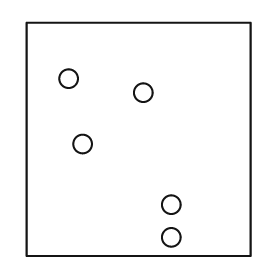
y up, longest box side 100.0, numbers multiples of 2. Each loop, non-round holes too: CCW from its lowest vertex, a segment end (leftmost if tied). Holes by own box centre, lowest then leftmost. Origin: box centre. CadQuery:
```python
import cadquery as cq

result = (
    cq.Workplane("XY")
    .moveTo(-48.0, -50.0)
    .lineTo(48.0, -50.0)
    .lineTo(48.0, 50.0)
    .lineTo(-48.0, 50.0)
    .close()
    .moveTo(14.0, -42.0)
    .circle(4.0)
    .moveTo(14.0, -28.0)
    .circle(4.0)
    .moveTo(-24.0, -2.0)
    .circle(4.0)
    .moveTo(2.0, 20.0)
    .circle(4.0)
    .moveTo(-30.0, 26.0)
    .circle(4.0)
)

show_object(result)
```